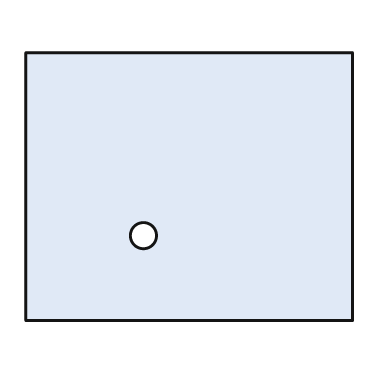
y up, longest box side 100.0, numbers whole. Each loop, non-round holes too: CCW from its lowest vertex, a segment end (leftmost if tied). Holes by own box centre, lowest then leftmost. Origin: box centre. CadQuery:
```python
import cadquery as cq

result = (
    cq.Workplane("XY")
    .moveTo(-50.0, -41.0)
    .lineTo(50.0, -41.0)
    .lineTo(50.0, 41.0)
    .lineTo(-50.0, 41.0)
    .close()
    .moveTo(-14.0, -15.0)
    .circle(4.0)
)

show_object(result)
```